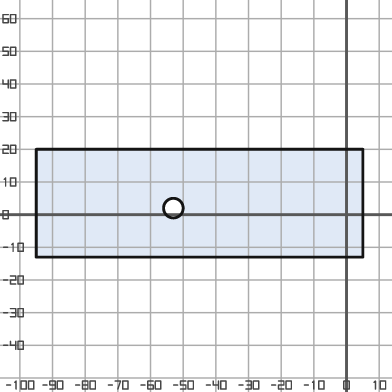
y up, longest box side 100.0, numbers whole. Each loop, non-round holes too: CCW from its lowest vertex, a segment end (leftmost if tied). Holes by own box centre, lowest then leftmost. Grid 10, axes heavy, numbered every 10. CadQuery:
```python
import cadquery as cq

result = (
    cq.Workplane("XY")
    .moveTo(-95.0, -13.0)
    .lineTo(5.0, -13.0)
    .lineTo(5.0, 20.0)
    .lineTo(-95.0, 20.0)
    .close()
    .moveTo(-53.0, 2.0)
    .circle(3.0)
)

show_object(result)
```